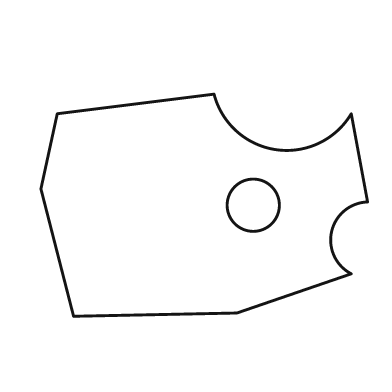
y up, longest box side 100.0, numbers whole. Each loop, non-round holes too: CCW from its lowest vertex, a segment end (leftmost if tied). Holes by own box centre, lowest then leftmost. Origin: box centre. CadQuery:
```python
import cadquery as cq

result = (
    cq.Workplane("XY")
    .moveTo(-40.0, -34.0)
    .lineTo(10.0, -33.0)
    .lineTo(45.0, -21.0)
    .threePointArc((39.0, -8.0), (50.0, 1.0))
    .lineTo(45.0, 28.0)
    .threePointArc((22.0, 17.0), (3.0, 34.0))
    .lineTo(-45.0, 28.0)
    .lineTo(-50.0, 5.0)
    .close()
    .moveTo(15.0, 0.0)
    .circle(8.0)
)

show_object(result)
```